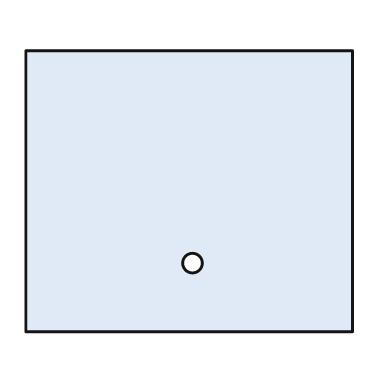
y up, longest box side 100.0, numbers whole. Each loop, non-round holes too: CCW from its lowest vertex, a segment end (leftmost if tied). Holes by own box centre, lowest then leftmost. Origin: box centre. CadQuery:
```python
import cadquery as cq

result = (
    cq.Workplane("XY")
    .moveTo(-50.0, -43.0)
    .lineTo(50.0, -43.0)
    .lineTo(50.0, 43.0)
    .lineTo(-50.0, 43.0)
    .close()
    .moveTo(1.0, -22.0)
    .circle(3.0)
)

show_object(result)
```